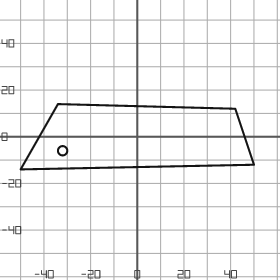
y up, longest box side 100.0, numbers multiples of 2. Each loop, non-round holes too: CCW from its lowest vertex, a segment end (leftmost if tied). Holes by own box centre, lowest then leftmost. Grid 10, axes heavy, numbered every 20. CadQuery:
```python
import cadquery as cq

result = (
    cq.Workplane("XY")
    .moveTo(-50.0, -14.0)
    .lineTo(50.0, -12.0)
    .lineTo(42.0, 12.0)
    .lineTo(-34.0, 14.0)
    .close()
    .moveTo(-32.0, -6.0)
    .circle(2.0)
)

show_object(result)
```